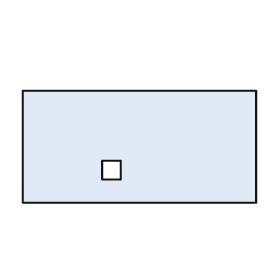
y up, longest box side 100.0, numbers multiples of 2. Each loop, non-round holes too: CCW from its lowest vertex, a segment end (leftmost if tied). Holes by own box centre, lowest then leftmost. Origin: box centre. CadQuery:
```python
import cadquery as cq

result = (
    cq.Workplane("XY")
    .moveTo(-50.0, -24.0)
    .lineTo(50.0, -24.0)
    .lineTo(50.0, 24.0)
    .lineTo(-50.0, 24.0)
    .close()
    .moveTo(-16.0, -14.0)
    .lineTo(-8.0, -14.0)
    .lineTo(-8.0, -6.0)
    .lineTo(-16.0, -6.0)
    .close()
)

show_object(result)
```